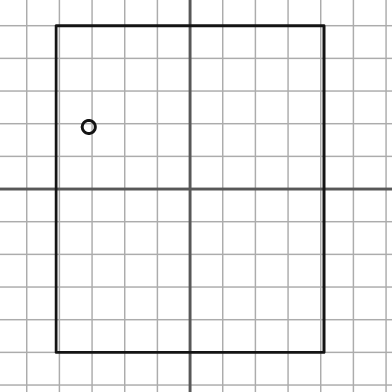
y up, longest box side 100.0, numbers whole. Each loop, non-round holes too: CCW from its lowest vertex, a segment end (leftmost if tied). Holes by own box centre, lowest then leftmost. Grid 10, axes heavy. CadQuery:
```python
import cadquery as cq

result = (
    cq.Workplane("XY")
    .moveTo(-41.0, -50.0)
    .lineTo(41.0, -50.0)
    .lineTo(41.0, 50.0)
    .lineTo(-41.0, 50.0)
    .close()
    .moveTo(-31.0, 19.0)
    .circle(2.0)
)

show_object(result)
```